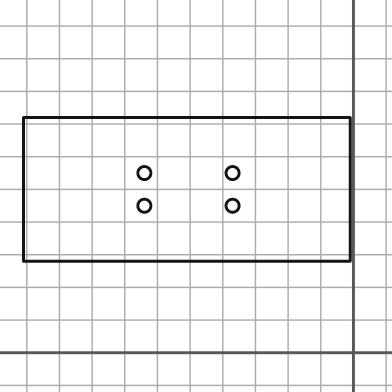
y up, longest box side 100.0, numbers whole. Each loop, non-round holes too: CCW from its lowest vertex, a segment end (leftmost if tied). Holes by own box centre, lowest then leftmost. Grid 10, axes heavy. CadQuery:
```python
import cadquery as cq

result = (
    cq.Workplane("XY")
    .moveTo(-101.0, 28.0)
    .lineTo(-1.0, 28.0)
    .lineTo(-1.0, 72.0)
    .lineTo(-101.0, 72.0)
    .close()
    .moveTo(-64.0, 45.0)
    .circle(2.0)
    .moveTo(-37.0, 45.0)
    .circle(2.0)
    .moveTo(-64.0, 55.0)
    .circle(2.0)
    .moveTo(-37.0, 55.0)
    .circle(2.0)
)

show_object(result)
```